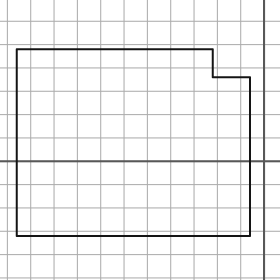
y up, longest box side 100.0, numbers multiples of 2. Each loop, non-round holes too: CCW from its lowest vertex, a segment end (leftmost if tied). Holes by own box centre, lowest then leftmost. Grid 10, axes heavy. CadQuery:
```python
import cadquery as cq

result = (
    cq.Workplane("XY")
    .moveTo(-106.0, -32.0)
    .lineTo(-6.0, -32.0)
    .lineTo(-6.0, 36.0)
    .lineTo(-22.0, 36.0)
    .lineTo(-22.0, 48.0)
    .lineTo(-106.0, 48.0)
    .close()
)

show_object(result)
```